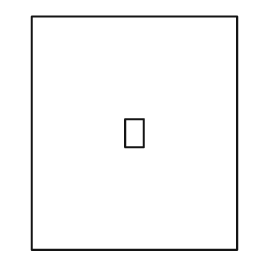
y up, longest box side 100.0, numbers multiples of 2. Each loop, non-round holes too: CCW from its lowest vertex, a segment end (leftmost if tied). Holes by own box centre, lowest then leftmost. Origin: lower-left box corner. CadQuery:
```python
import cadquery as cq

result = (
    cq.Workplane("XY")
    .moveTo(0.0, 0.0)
    .lineTo(88.0, 0.0)
    .lineTo(88.0, 100.0)
    .lineTo(0.0, 100.0)
    .close()
    .moveTo(40.0, 44.0)
    .lineTo(48.0, 44.0)
    .lineTo(48.0, 56.0)
    .lineTo(40.0, 56.0)
    .close()
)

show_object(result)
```